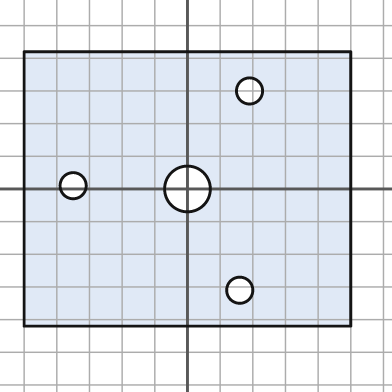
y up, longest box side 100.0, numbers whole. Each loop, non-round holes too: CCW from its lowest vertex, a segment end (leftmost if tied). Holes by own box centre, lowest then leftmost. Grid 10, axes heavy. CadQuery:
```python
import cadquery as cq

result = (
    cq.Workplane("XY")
    .moveTo(-50.0, -42.0)
    .lineTo(50.0, -42.0)
    .lineTo(50.0, 42.0)
    .lineTo(-50.0, 42.0)
    .close()
    .moveTo(16.0, -31.0)
    .circle(4.0)
    .moveTo(0.0, 0.0)
    .circle(7.0)
    .moveTo(-35.0, 1.0)
    .circle(4.0)
    .moveTo(19.0, 30.0)
    .circle(4.0)
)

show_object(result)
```